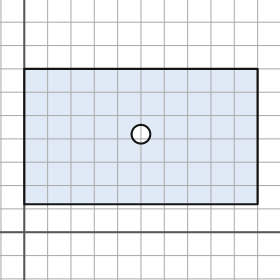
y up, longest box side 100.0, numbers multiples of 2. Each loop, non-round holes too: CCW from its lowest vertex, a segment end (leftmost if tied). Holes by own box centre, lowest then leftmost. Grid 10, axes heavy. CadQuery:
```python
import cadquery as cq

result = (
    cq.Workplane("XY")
    .moveTo(0.0, 12.0)
    .lineTo(100.0, 12.0)
    .lineTo(100.0, 70.0)
    .lineTo(0.0, 70.0)
    .close()
    .moveTo(50.0, 42.0)
    .circle(4.0)
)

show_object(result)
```